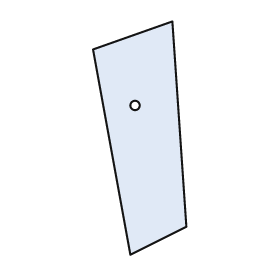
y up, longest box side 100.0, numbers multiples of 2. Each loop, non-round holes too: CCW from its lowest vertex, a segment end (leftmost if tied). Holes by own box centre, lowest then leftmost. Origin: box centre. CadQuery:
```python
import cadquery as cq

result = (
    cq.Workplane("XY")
    .moveTo(-4.0, -50.0)
    .lineTo(20.0, -38.0)
    .lineTo(14.0, 50.0)
    .lineTo(-20.0, 38.0)
    .close()
    .moveTo(-2.0, 14.0)
    .circle(2.0)
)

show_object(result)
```